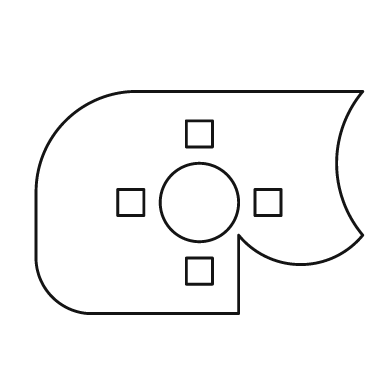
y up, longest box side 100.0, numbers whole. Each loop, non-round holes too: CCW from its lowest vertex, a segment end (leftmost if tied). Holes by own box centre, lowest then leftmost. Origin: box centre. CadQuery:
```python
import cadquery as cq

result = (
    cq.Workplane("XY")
    .moveTo(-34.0, -34.0)
    .lineTo(12.0, -34.0)
    .lineTo(12.0, -10.0)
    .threePointArc((31.0, -19.0), (50.0, -10.0))
    .threePointArc((42.0, 12.0), (50.0, 34.0))
    .lineTo(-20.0, 34.0)
    .threePointArc((-41.0, 25.0), (-50.0, 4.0))
    .lineTo(-50.0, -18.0)
    .threePointArc((-45.0, -29.0), (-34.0, -34.0))
    .close()
    .moveTo(-4.0, -25.0)
    .lineTo(4.0, -25.0)
    .lineTo(4.0, -17.0)
    .lineTo(-4.0, -17.0)
    .close()
    .moveTo(-25.0, -4.0)
    .lineTo(-17.0, -4.0)
    .lineTo(-17.0, 4.0)
    .lineTo(-25.0, 4.0)
    .close()
    .moveTo(0.0, 0.0)
    .circle(12.0)
    .moveTo(17.0, -4.0)
    .lineTo(25.0, -4.0)
    .lineTo(25.0, 4.0)
    .lineTo(17.0, 4.0)
    .close()
    .moveTo(-4.0, 17.0)
    .lineTo(4.0, 17.0)
    .lineTo(4.0, 25.0)
    .lineTo(-4.0, 25.0)
    .close()
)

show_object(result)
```